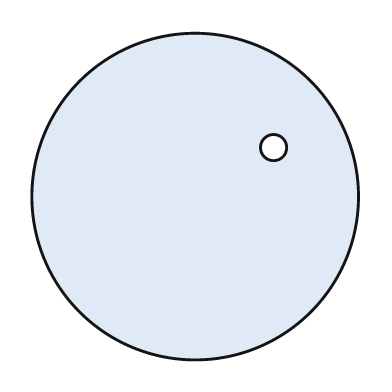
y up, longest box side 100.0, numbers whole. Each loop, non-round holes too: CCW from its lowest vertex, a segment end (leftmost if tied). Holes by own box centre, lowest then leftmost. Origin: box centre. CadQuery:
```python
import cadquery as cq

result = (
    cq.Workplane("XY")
    .moveTo(0.0, 0.0)
    .circle(50.0)
    .moveTo(24.0, 15.0)
    .circle(4.0)
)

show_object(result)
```